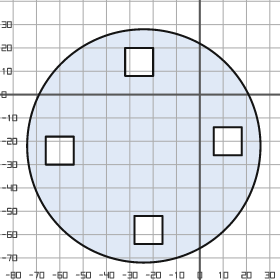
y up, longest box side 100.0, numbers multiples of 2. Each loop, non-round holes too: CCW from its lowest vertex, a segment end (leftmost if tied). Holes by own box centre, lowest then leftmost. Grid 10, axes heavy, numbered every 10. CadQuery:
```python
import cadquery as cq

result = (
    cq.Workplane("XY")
    .moveTo(-24.0, -22.0)
    .circle(50.0)
    .moveTo(-28.0, -64.0)
    .lineTo(-16.0, -64.0)
    .lineTo(-16.0, -52.0)
    .lineTo(-28.0, -52.0)
    .close()
    .moveTo(-66.0, -30.0)
    .lineTo(-54.0, -30.0)
    .lineTo(-54.0, -18.0)
    .lineTo(-66.0, -18.0)
    .close()
    .moveTo(6.0, -26.0)
    .lineTo(18.0, -26.0)
    .lineTo(18.0, -14.0)
    .lineTo(6.0, -14.0)
    .close()
    .moveTo(-32.0, 8.0)
    .lineTo(-20.0, 8.0)
    .lineTo(-20.0, 20.0)
    .lineTo(-32.0, 20.0)
    .close()
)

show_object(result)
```